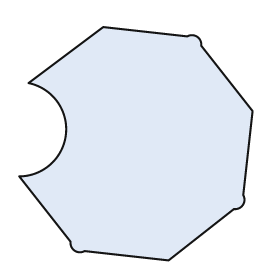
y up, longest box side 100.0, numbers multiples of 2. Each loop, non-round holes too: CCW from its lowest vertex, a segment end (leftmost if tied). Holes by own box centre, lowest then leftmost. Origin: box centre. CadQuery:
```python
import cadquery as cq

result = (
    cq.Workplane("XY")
    .moveTo(14.0, -50.0)
    .lineTo(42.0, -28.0)
    .threePointArc((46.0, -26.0), (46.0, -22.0))
    .lineTo(50.0, 14.0)
    .lineTo(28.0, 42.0)
    .threePointArc((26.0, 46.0), (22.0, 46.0))
    .lineTo(-14.0, 50.0)
    .lineTo(-46.0, 26.0)
    .threePointArc((-30.0, 4.0), (-50.0, -14.0))
    .lineTo(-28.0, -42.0)
    .threePointArc((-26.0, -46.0), (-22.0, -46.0))
    .close()
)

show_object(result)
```